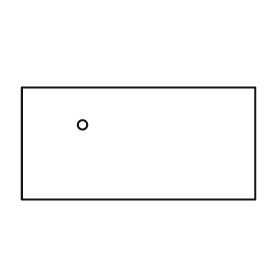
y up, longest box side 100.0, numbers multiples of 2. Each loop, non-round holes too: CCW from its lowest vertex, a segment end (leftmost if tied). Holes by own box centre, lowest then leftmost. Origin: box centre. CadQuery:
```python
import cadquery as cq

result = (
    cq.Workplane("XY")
    .moveTo(-50.0, -24.0)
    .lineTo(50.0, -24.0)
    .lineTo(50.0, 24.0)
    .lineTo(-50.0, 24.0)
    .close()
    .moveTo(-24.0, 8.0)
    .circle(2.0)
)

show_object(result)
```